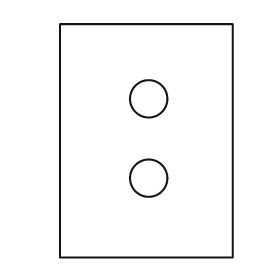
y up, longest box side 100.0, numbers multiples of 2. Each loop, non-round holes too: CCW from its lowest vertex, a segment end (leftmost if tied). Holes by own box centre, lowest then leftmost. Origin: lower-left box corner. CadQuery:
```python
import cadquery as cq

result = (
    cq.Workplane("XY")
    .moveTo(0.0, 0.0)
    .lineTo(74.0, 0.0)
    .lineTo(74.0, 100.0)
    .lineTo(0.0, 100.0)
    .close()
    .moveTo(38.0, 34.0)
    .circle(8.0)
    .moveTo(38.0, 68.0)
    .circle(8.0)
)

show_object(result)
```